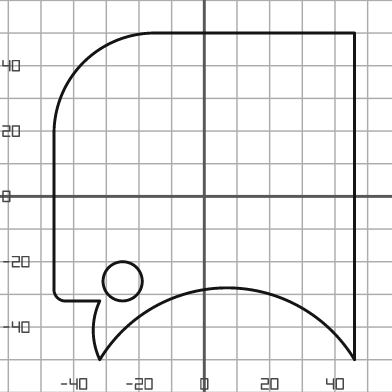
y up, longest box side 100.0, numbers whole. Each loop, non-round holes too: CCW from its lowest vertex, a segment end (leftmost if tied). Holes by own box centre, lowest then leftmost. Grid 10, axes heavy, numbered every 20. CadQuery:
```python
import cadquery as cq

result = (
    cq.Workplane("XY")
    .moveTo(-32.0, -50.0)
    .threePointArc((7.0, -28.0), (46.0, -50.0))
    .lineTo(46.0, 50.0)
    .lineTo(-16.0, 50.0)
    .threePointArc((-37.0, 41.0), (-46.0, 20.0))
    .lineTo(-46.0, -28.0)
    .threePointArc((-45.0, -31.0), (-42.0, -32.0))
    .lineTo(-32.0, -32.0)
    .threePointArc((-34.0, -41.0), (-32.0, -50.0))
    .close()
    .moveTo(-25.0, -26.0)
    .circle(6.0)
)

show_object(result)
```